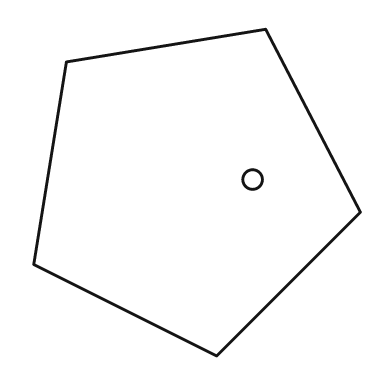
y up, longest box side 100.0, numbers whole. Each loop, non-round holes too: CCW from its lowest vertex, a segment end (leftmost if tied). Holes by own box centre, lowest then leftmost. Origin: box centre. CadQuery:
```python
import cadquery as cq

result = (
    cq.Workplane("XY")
    .moveTo(6.0, -50.0)
    .lineTo(50.0, -6.0)
    .lineTo(21.0, 50.0)
    .lineTo(-40.0, 40.0)
    .lineTo(-50.0, -22.0)
    .close()
    .moveTo(17.0, 4.0)
    .circle(3.0)
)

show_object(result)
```